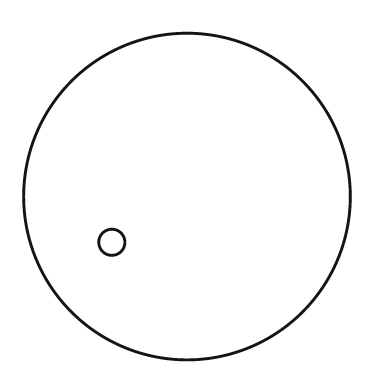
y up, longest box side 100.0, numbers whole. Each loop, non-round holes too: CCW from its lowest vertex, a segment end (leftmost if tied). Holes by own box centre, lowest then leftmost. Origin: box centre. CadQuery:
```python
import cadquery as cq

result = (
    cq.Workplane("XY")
    .moveTo(0.0, 0.0)
    .circle(50.0)
    .moveTo(-23.0, -14.0)
    .circle(4.0)
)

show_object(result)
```